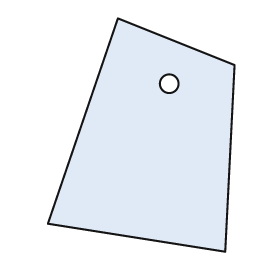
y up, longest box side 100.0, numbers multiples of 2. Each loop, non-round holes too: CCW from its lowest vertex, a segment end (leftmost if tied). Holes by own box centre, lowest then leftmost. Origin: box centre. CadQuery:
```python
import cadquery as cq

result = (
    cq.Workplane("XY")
    .moveTo(36.0, -50.0)
    .lineTo(40.0, 30.0)
    .lineTo(-10.0, 50.0)
    .lineTo(-40.0, -38.0)
    .close()
    .moveTo(12.0, 22.0)
    .circle(4.0)
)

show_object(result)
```